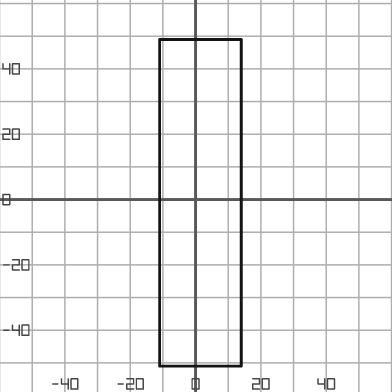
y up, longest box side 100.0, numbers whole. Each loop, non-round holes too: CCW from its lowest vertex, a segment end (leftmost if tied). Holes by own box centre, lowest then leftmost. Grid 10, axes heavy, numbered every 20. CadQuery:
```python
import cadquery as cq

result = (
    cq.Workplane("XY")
    .moveTo(-11.0, -51.0)
    .lineTo(14.0, -51.0)
    .lineTo(14.0, 49.0)
    .lineTo(-11.0, 49.0)
    .close()
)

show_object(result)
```